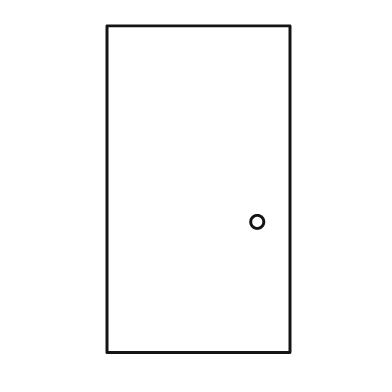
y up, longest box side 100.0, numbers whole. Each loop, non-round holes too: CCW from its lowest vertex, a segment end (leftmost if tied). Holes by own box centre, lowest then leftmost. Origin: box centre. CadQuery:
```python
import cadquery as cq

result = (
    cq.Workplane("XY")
    .moveTo(-28.0, -50.0)
    .lineTo(28.0, -50.0)
    .lineTo(28.0, 50.0)
    .lineTo(-28.0, 50.0)
    .close()
    .moveTo(18.0, -10.0)
    .circle(2.0)
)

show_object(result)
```